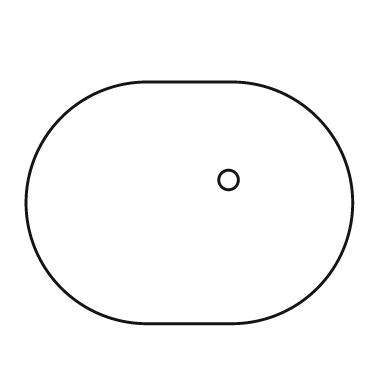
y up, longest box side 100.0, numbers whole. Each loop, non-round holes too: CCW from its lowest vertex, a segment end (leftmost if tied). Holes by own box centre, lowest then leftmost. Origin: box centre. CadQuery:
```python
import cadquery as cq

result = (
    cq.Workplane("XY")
    .moveTo(-13.0, -37.0)
    .lineTo(13.0, -37.0)
    .threePointArc((50.0, 0.0), (13.0, 37.0))
    .lineTo(-13.0, 37.0)
    .threePointArc((-50.0, 0.0), (-13.0, -37.0))
    .close()
    .moveTo(12.0, 7.0)
    .circle(3.0)
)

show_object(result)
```